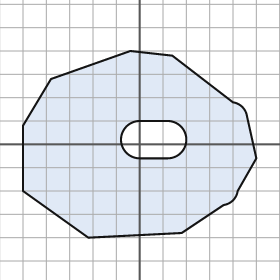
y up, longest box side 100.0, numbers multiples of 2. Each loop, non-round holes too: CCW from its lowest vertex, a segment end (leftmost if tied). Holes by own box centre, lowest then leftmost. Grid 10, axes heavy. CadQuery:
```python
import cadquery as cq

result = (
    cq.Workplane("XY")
    .moveTo(-22.0, -40.0)
    .lineTo(18.0, -38.0)
    .lineTo(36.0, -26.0)
    .threePointArc((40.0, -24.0), (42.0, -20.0))
    .lineTo(50.0, -6.0)
    .lineTo(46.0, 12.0)
    .threePointArc((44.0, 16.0), (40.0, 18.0))
    .lineTo(14.0, 38.0)
    .lineTo(-4.0, 40.0)
    .lineTo(-38.0, 28.0)
    .lineTo(-50.0, 8.0)
    .lineTo(-50.0, -20.0)
    .close()
    .moveTo(0.0, -6.0)
    .lineTo(12.0, -6.0)
    .threePointArc((20.0, 2.0), (12.0, 10.0))
    .lineTo(0.0, 10.0)
    .threePointArc((-8.0, 2.0), (0.0, -6.0))
    .close()
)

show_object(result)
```